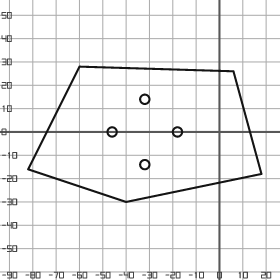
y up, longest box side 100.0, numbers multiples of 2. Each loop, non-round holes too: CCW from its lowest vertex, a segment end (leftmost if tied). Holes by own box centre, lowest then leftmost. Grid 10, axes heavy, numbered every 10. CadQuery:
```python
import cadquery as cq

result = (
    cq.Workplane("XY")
    .moveTo(-40.0, -30.0)
    .lineTo(18.0, -18.0)
    .lineTo(6.0, 26.0)
    .lineTo(-60.0, 28.0)
    .lineTo(-82.0, -16.0)
    .close()
    .moveTo(-32.0, -14.0)
    .circle(2.0)
    .moveTo(-46.0, 0.0)
    .circle(2.0)
    .moveTo(-18.0, 0.0)
    .circle(2.0)
    .moveTo(-32.0, 14.0)
    .circle(2.0)
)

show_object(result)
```